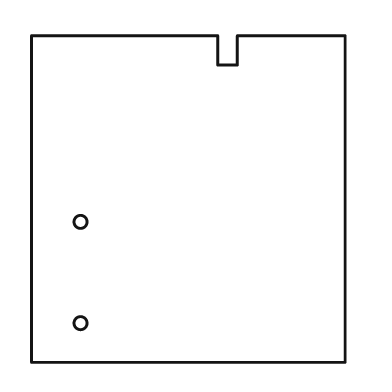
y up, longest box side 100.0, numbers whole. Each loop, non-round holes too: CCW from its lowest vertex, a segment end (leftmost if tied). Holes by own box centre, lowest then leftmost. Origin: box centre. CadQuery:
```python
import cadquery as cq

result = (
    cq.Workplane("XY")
    .moveTo(-48.0, -50.0)
    .lineTo(48.0, -50.0)
    .lineTo(48.0, 50.0)
    .lineTo(15.0, 50.0)
    .lineTo(15.0, 41.0)
    .lineTo(9.0, 41.0)
    .lineTo(9.0, 50.0)
    .lineTo(-48.0, 50.0)
    .close()
    .moveTo(-33.0, -38.0)
    .circle(2.0)
    .moveTo(-33.0, -7.0)
    .circle(2.0)
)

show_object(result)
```